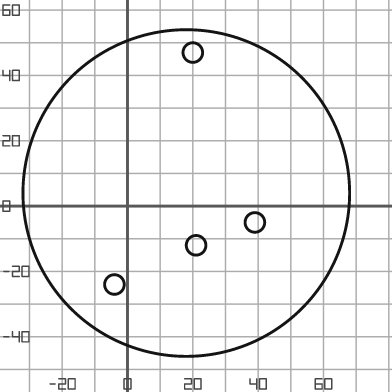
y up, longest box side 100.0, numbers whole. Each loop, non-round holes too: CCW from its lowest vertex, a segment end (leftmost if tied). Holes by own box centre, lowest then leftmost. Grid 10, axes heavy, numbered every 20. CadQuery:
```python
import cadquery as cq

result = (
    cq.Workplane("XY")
    .moveTo(18.0, 4.0)
    .circle(50.0)
    .moveTo(-4.0, -24.0)
    .circle(3.0)
    .moveTo(21.0, -12.0)
    .circle(3.0)
    .moveTo(39.0, -5.0)
    .circle(3.0)
    .moveTo(20.0, 47.0)
    .circle(3.0)
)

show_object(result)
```